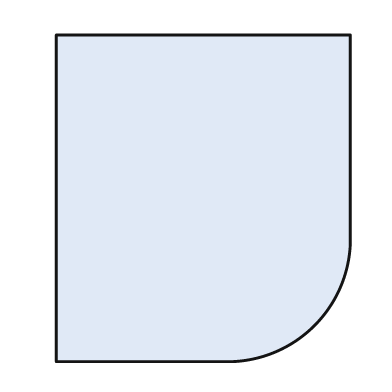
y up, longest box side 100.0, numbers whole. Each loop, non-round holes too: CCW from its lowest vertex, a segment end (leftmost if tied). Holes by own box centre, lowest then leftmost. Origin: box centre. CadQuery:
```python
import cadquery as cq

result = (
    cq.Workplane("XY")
    .moveTo(-45.0, -50.0)
    .lineTo(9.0, -50.0)
    .threePointArc((34.0, -39.0), (45.0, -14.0))
    .lineTo(45.0, 50.0)
    .lineTo(-45.0, 50.0)
    .close()
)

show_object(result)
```